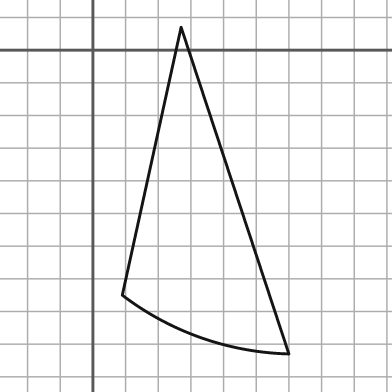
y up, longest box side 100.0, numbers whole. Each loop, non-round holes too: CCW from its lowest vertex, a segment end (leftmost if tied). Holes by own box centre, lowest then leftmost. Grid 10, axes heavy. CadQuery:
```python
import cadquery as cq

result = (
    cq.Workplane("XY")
    .moveTo(60.0, -93.0)
    .lineTo(27.0, 7.0)
    .lineTo(9.0, -75.0)
    .threePointArc((33.0, -88.0), (60.0, -93.0))
    .close()
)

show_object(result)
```